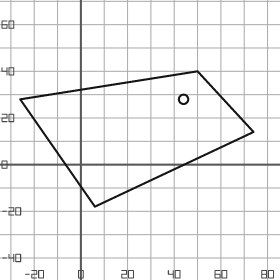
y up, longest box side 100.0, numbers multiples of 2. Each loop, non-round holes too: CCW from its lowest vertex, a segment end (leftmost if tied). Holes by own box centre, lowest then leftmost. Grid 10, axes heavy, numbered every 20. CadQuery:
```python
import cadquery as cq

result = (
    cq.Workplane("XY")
    .moveTo(6.0, -18.0)
    .lineTo(74.0, 14.0)
    .lineTo(50.0, 40.0)
    .lineTo(-26.0, 28.0)
    .close()
    .moveTo(44.0, 28.0)
    .circle(2.0)
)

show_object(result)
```